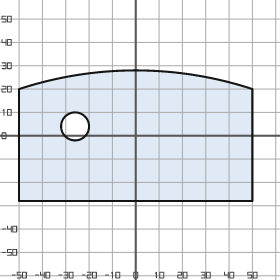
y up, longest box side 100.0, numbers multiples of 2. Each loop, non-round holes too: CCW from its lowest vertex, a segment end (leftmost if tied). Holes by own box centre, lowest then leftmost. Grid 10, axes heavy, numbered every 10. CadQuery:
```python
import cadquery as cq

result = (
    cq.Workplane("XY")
    .moveTo(-50.0, -28.0)
    .lineTo(50.0, -28.0)
    .lineTo(50.0, 20.0)
    .threePointArc((0.0, 28.0), (-50.0, 20.0))
    .close()
    .moveTo(-26.0, 4.0)
    .circle(6.0)
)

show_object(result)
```